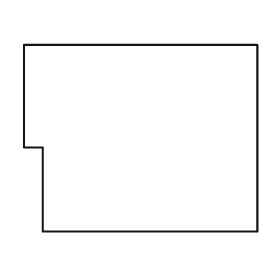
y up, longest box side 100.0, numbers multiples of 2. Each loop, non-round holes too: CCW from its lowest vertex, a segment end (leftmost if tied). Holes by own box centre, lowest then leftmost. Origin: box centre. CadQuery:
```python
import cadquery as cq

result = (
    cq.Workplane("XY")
    .moveTo(-42.0, -40.0)
    .lineTo(50.0, -40.0)
    .lineTo(50.0, 40.0)
    .lineTo(-50.0, 40.0)
    .lineTo(-50.0, -4.0)
    .lineTo(-42.0, -4.0)
    .close()
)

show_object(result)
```